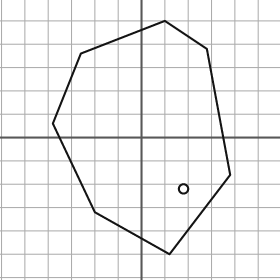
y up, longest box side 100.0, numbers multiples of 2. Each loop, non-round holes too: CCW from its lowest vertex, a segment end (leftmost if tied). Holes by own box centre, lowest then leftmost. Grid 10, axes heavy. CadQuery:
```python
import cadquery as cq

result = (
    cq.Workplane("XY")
    .moveTo(12.0, -50.0)
    .lineTo(38.0, -16.0)
    .lineTo(28.0, 38.0)
    .lineTo(10.0, 50.0)
    .lineTo(-26.0, 36.0)
    .lineTo(-38.0, 6.0)
    .lineTo(-20.0, -32.0)
    .close()
    .moveTo(18.0, -22.0)
    .circle(2.0)
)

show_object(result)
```